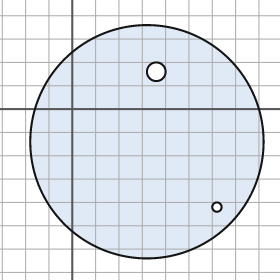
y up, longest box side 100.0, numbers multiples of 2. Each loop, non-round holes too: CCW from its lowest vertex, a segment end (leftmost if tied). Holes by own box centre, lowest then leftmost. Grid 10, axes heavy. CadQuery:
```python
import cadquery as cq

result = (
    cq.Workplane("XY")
    .moveTo(32.0, -14.0)
    .circle(50.0)
    .moveTo(62.0, -42.0)
    .circle(2.0)
    .moveTo(36.0, 16.0)
    .circle(4.0)
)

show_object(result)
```